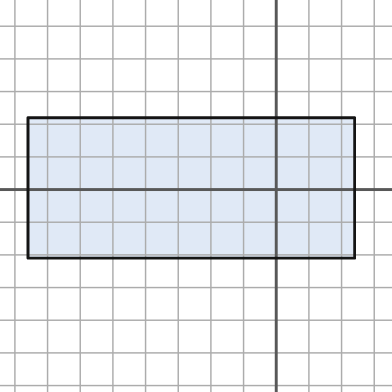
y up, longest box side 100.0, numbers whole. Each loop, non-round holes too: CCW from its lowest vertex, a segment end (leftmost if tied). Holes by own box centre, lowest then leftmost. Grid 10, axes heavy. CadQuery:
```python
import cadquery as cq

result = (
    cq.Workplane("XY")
    .moveTo(-76.0, -21.0)
    .lineTo(24.0, -21.0)
    .lineTo(24.0, 22.0)
    .lineTo(-76.0, 22.0)
    .close()
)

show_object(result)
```